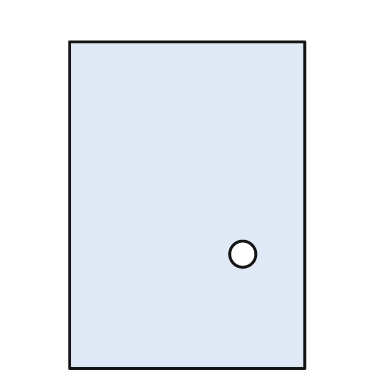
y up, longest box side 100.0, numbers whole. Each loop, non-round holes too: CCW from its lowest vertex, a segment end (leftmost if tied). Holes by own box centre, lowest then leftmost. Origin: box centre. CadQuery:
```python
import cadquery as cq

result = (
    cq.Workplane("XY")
    .moveTo(-36.0, -50.0)
    .lineTo(36.0, -50.0)
    .lineTo(36.0, 50.0)
    .lineTo(-36.0, 50.0)
    .close()
    .moveTo(17.0, -15.0)
    .circle(4.0)
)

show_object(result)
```